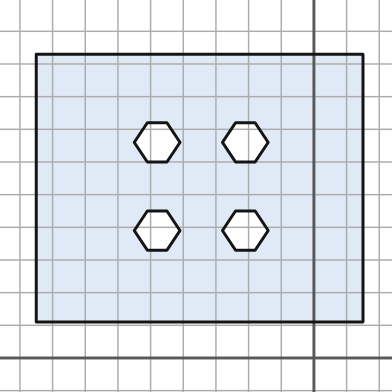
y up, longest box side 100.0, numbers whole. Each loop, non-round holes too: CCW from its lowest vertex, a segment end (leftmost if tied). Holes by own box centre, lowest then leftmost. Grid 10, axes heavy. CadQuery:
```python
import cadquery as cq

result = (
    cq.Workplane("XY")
    .moveTo(-85.0, 11.0)
    .lineTo(15.0, 11.0)
    .lineTo(15.0, 93.0)
    .lineTo(-85.0, 93.0)
    .close()
    .moveTo(-51.0, 33.0)
    .lineTo(-45.0, 33.0)
    .lineTo(-41.0, 39.0)
    .lineTo(-45.0, 45.0)
    .lineTo(-51.0, 45.0)
    .lineTo(-55.0, 39.0)
    .close()
    .moveTo(-24.0, 33.0)
    .lineTo(-18.0, 33.0)
    .lineTo(-14.0, 39.0)
    .lineTo(-18.0, 45.0)
    .lineTo(-24.0, 45.0)
    .lineTo(-28.0, 39.0)
    .close()
    .moveTo(-51.0, 60.0)
    .lineTo(-45.0, 60.0)
    .lineTo(-41.0, 66.0)
    .lineTo(-45.0, 72.0)
    .lineTo(-51.0, 72.0)
    .lineTo(-55.0, 66.0)
    .close()
    .moveTo(-24.0, 60.0)
    .lineTo(-18.0, 60.0)
    .lineTo(-14.0, 66.0)
    .lineTo(-18.0, 72.0)
    .lineTo(-24.0, 72.0)
    .lineTo(-28.0, 66.0)
    .close()
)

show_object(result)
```